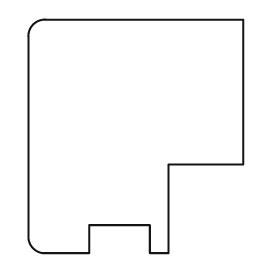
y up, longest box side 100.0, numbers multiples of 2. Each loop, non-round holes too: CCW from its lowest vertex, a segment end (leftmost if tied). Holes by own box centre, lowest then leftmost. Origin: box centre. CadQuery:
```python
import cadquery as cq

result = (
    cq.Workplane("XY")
    .moveTo(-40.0, -50.0)
    .lineTo(-20.0, -50.0)
    .lineTo(-20.0, -38.0)
    .lineTo(6.0, -38.0)
    .lineTo(6.0, -50.0)
    .lineTo(14.0, -50.0)
    .lineTo(14.0, -12.0)
    .lineTo(46.0, -12.0)
    .lineTo(46.0, 50.0)
    .lineTo(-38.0, 50.0)
    .threePointArc((-44.0, 48.0), (-46.0, 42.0))
    .lineTo(-46.0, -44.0)
    .threePointArc((-44.0, -48.0), (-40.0, -50.0))
    .close()
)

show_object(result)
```